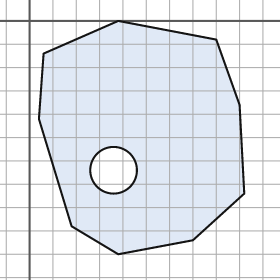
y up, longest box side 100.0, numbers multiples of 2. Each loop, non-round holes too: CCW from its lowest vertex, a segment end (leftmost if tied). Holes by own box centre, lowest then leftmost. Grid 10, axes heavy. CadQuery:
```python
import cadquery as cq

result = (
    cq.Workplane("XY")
    .moveTo(38.0, -100.0)
    .lineTo(70.0, -94.0)
    .lineTo(92.0, -74.0)
    .lineTo(90.0, -36.0)
    .lineTo(80.0, -8.0)
    .lineTo(38.0, 0.0)
    .lineTo(6.0, -14.0)
    .lineTo(4.0, -42.0)
    .lineTo(18.0, -88.0)
    .close()
    .moveTo(36.0, -64.0)
    .circle(10.0)
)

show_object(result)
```